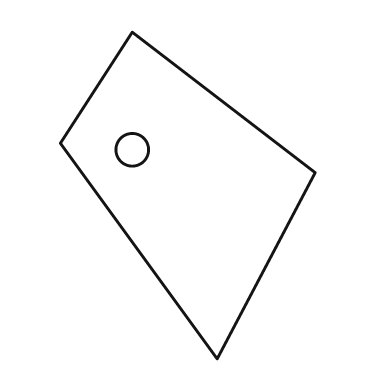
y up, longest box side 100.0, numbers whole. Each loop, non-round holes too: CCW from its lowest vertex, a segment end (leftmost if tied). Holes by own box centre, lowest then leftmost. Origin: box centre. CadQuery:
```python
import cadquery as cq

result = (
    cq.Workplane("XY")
    .moveTo(9.0, -50.0)
    .lineTo(39.0, 7.0)
    .lineTo(-17.0, 50.0)
    .lineTo(-39.0, 16.0)
    .close()
    .moveTo(-17.0, 14.0)
    .circle(5.0)
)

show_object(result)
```